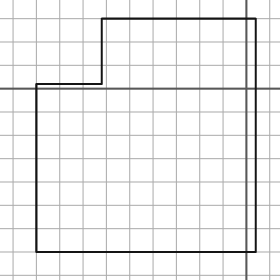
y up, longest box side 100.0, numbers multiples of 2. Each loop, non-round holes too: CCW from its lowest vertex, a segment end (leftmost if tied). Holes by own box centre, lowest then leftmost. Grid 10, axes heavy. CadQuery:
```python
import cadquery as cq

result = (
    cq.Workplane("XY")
    .moveTo(-90.0, -70.0)
    .lineTo(4.0, -70.0)
    .lineTo(4.0, 30.0)
    .lineTo(-62.0, 30.0)
    .lineTo(-62.0, 2.0)
    .lineTo(-90.0, 2.0)
    .close()
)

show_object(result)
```